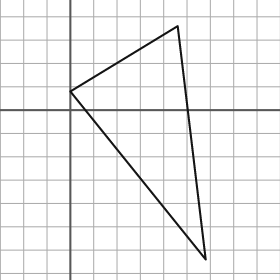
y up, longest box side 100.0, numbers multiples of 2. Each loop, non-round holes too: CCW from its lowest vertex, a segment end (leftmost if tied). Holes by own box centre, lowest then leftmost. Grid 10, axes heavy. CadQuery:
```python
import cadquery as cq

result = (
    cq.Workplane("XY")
    .moveTo(58.0, -64.0)
    .lineTo(46.0, 36.0)
    .lineTo(0.0, 8.0)
    .close()
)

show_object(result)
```